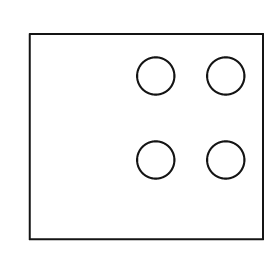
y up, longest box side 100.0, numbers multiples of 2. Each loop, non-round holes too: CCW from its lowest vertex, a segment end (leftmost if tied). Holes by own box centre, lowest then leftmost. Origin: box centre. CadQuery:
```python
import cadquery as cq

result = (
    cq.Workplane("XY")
    .moveTo(-50.0, -44.0)
    .lineTo(50.0, -44.0)
    .lineTo(50.0, 44.0)
    .lineTo(-50.0, 44.0)
    .close()
    .moveTo(4.0, -10.0)
    .circle(8.0)
    .moveTo(34.0, -10.0)
    .circle(8.0)
    .moveTo(4.0, 26.0)
    .circle(8.0)
    .moveTo(34.0, 26.0)
    .circle(8.0)
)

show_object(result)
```